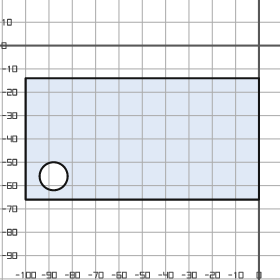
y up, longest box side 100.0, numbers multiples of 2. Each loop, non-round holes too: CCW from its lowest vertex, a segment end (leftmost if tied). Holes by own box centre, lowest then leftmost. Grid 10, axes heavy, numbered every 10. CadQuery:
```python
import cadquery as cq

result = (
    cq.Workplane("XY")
    .moveTo(-100.0, -66.0)
    .lineTo(0.0, -66.0)
    .lineTo(0.0, -14.0)
    .lineTo(-100.0, -14.0)
    .close()
    .moveTo(-88.0, -56.0)
    .circle(6.0)
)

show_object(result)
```